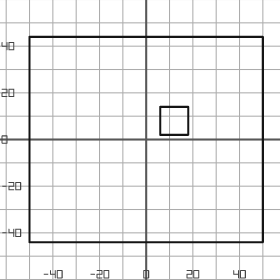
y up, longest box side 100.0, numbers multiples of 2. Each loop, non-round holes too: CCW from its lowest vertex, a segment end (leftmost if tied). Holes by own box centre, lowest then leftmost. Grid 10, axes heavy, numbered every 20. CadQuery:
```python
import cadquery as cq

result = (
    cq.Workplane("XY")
    .moveTo(-50.0, -44.0)
    .lineTo(50.0, -44.0)
    .lineTo(50.0, 44.0)
    .lineTo(-50.0, 44.0)
    .close()
    .moveTo(6.0, 2.0)
    .lineTo(18.0, 2.0)
    .lineTo(18.0, 14.0)
    .lineTo(6.0, 14.0)
    .close()
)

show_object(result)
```